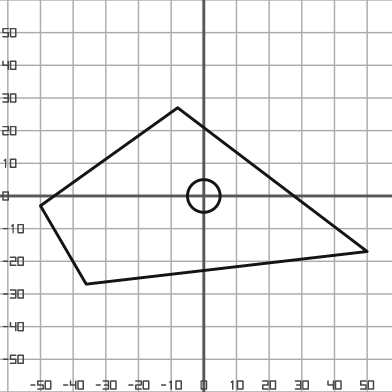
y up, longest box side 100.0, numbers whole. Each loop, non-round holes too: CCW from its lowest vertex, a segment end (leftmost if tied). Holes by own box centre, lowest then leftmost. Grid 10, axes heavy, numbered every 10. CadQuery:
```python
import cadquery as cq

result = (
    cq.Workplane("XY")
    .moveTo(-36.0, -27.0)
    .lineTo(50.0, -17.0)
    .lineTo(-8.0, 27.0)
    .lineTo(-50.0, -3.0)
    .close()
    .moveTo(0.0, 0.0)
    .circle(5.0)
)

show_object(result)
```